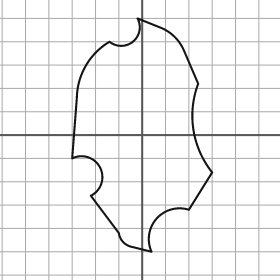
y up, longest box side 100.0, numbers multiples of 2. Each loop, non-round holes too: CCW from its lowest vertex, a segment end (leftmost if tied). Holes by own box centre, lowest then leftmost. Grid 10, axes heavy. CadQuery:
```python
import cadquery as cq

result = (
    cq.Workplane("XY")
    .moveTo(4.0, -50.0)
    .threePointArc((6.0, -36.0), (20.0, -32.0))
    .lineTo(30.0, -16.0)
    .threePointArc((22.0, 2.0), (24.0, 22.0))
    .lineTo(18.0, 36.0)
    .threePointArc((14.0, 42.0), (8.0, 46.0))
    .lineTo(-2.0, 50.0)
    .threePointArc((-4.0, 40.0), (-14.0, 40.0))
    .threePointArc((-24.0, 30.0), (-28.0, 16.0))
    .lineTo(-30.0, -10.0)
    .threePointArc((-18.0, -14.0), (-22.0, -26.0))
    .lineTo(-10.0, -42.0)
    .threePointArc((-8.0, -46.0), (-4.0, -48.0))
    .close()
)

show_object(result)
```